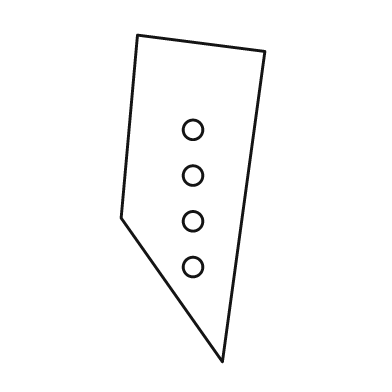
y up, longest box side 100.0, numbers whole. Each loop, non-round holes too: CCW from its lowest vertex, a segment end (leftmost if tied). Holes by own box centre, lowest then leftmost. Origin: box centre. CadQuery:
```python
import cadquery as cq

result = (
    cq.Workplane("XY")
    .moveTo(9.0, -50.0)
    .lineTo(22.0, 45.0)
    .lineTo(-17.0, 50.0)
    .lineTo(-22.0, -6.0)
    .close()
    .moveTo(0.0, -21.0)
    .circle(3.0)
    .moveTo(0.0, -7.0)
    .circle(3.0)
    .moveTo(0.0, 7.0)
    .circle(3.0)
    .moveTo(0.0, 21.0)
    .circle(3.0)
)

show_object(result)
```